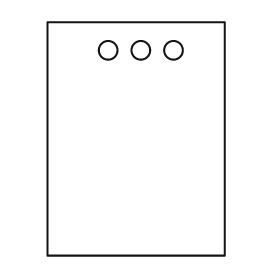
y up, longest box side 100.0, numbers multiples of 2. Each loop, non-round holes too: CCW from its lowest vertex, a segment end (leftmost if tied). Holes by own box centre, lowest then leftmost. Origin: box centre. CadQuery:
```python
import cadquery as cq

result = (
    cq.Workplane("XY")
    .moveTo(-38.0, -50.0)
    .lineTo(38.0, -50.0)
    .lineTo(38.0, 50.0)
    .lineTo(-38.0, 50.0)
    .close()
    .moveTo(-12.0, 38.0)
    .circle(4.0)
    .moveTo(2.0, 38.0)
    .circle(4.0)
    .moveTo(16.0, 38.0)
    .circle(4.0)
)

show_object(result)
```